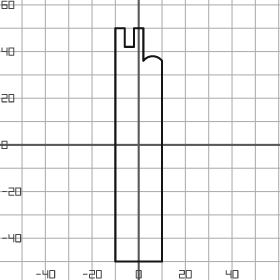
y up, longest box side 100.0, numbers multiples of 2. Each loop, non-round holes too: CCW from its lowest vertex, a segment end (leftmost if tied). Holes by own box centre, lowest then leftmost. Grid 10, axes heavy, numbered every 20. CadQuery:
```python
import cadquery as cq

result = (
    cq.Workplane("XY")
    .moveTo(-10.0, -50.0)
    .lineTo(10.0, -50.0)
    .lineTo(10.0, 36.0)
    .threePointArc((6.0, 38.0), (2.0, 36.0))
    .lineTo(2.0, 50.0)
    .lineTo(-2.0, 50.0)
    .lineTo(-2.0, 42.0)
    .lineTo(-6.0, 42.0)
    .lineTo(-6.0, 50.0)
    .lineTo(-10.0, 50.0)
    .close()
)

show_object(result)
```